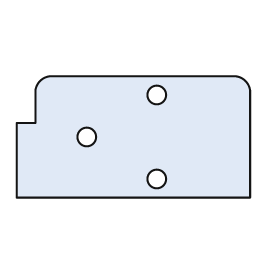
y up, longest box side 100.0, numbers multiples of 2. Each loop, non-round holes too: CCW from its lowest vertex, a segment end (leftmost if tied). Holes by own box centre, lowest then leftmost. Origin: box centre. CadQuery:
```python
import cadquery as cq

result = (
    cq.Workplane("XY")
    .moveTo(-50.0, -26.0)
    .lineTo(50.0, -26.0)
    .lineTo(50.0, 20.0)
    .threePointArc((48.0, 24.0), (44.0, 26.0))
    .lineTo(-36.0, 26.0)
    .threePointArc((-40.0, 24.0), (-42.0, 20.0))
    .lineTo(-42.0, 6.0)
    .lineTo(-50.0, 6.0)
    .close()
    .moveTo(10.0, -18.0)
    .circle(4.0)
    .moveTo(-20.0, 0.0)
    .circle(4.0)
    .moveTo(10.0, 18.0)
    .circle(4.0)
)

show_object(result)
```